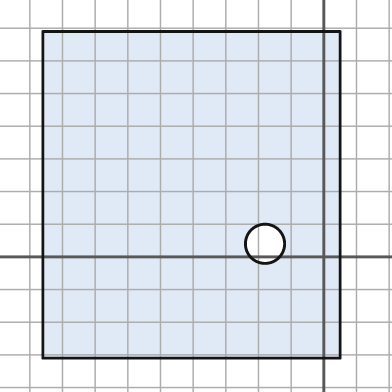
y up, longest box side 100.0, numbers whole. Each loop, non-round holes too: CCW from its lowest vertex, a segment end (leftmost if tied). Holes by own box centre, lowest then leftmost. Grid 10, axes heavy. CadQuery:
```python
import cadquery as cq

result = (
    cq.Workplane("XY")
    .moveTo(-86.0, -31.0)
    .lineTo(5.0, -31.0)
    .lineTo(5.0, 69.0)
    .lineTo(-86.0, 69.0)
    .close()
    .moveTo(-18.0, 4.0)
    .circle(6.0)
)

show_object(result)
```